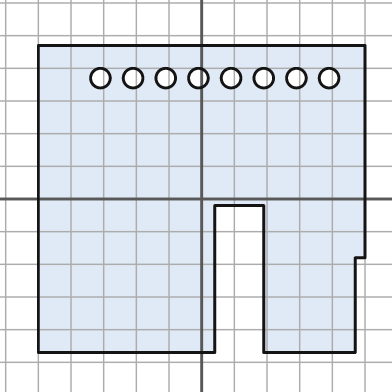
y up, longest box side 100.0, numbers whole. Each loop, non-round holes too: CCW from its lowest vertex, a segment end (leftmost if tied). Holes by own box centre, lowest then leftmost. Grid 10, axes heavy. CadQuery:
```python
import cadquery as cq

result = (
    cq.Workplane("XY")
    .moveTo(-50.0, -47.0)
    .lineTo(4.0, -47.0)
    .lineTo(4.0, -2.0)
    .lineTo(19.0, -2.0)
    .lineTo(19.0, -47.0)
    .lineTo(47.0, -47.0)
    .lineTo(47.0, -18.0)
    .lineTo(50.0, -18.0)
    .lineTo(50.0, 47.0)
    .lineTo(-50.0, 47.0)
    .close()
    .moveTo(-31.0, 37.0)
    .circle(3.0)
    .moveTo(-21.0, 37.0)
    .circle(3.0)
    .moveTo(-11.0, 37.0)
    .circle(3.0)
    .moveTo(-1.0, 37.0)
    .circle(3.0)
    .moveTo(9.0, 37.0)
    .circle(3.0)
    .moveTo(19.0, 37.0)
    .circle(3.0)
    .moveTo(29.0, 37.0)
    .circle(3.0)
    .moveTo(39.0, 37.0)
    .circle(3.0)
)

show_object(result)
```